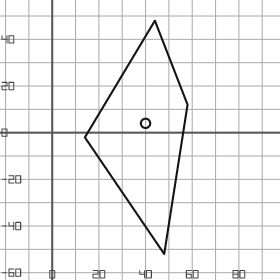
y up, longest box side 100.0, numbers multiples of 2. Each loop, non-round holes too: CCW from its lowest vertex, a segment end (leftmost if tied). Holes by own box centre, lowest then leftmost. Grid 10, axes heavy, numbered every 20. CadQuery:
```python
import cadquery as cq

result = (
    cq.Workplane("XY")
    .moveTo(48.0, -52.0)
    .lineTo(58.0, 12.0)
    .lineTo(44.0, 48.0)
    .lineTo(14.0, -2.0)
    .close()
    .moveTo(40.0, 4.0)
    .circle(2.0)
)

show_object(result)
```